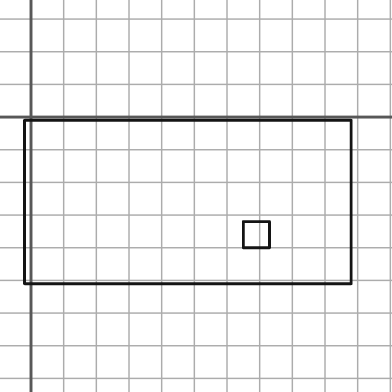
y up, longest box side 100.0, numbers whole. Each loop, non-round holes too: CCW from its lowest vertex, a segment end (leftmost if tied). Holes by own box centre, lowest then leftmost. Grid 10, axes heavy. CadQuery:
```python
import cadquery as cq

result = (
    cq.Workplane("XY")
    .moveTo(-2.0, -51.0)
    .lineTo(98.0, -51.0)
    .lineTo(98.0, -1.0)
    .lineTo(-2.0, -1.0)
    .close()
    .moveTo(65.0, -40.0)
    .lineTo(73.0, -40.0)
    .lineTo(73.0, -32.0)
    .lineTo(65.0, -32.0)
    .close()
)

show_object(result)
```